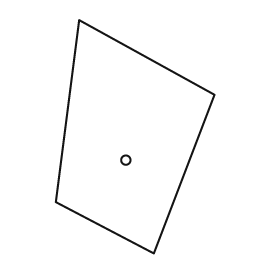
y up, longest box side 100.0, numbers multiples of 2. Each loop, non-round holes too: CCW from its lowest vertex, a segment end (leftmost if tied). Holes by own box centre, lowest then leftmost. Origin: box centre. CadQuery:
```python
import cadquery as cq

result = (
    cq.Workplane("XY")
    .moveTo(8.0, -50.0)
    .lineTo(34.0, 18.0)
    .lineTo(-24.0, 50.0)
    .lineTo(-34.0, -28.0)
    .close()
    .moveTo(-4.0, -10.0)
    .circle(2.0)
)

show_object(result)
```